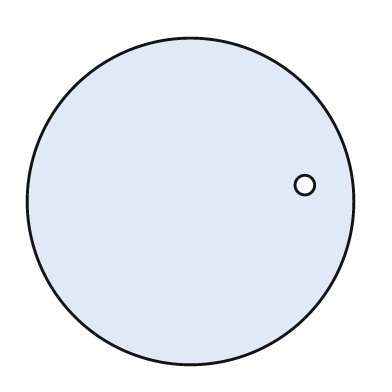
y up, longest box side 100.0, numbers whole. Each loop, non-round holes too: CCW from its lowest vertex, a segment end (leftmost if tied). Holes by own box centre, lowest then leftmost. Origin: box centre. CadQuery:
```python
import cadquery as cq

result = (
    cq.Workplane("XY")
    .moveTo(0.0, 0.0)
    .circle(50.0)
    .moveTo(35.0, 5.0)
    .circle(3.0)
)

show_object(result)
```